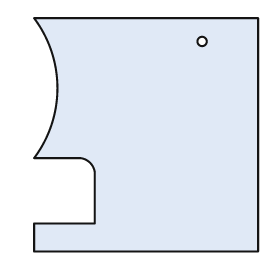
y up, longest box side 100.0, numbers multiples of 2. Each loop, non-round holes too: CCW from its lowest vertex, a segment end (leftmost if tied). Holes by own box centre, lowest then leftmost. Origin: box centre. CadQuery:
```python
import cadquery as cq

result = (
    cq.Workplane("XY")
    .moveTo(-48.0, -50.0)
    .lineTo(48.0, -50.0)
    .lineTo(48.0, 50.0)
    .lineTo(-48.0, 50.0)
    .threePointArc((-38.0, 20.0), (-48.0, -10.0))
    .lineTo(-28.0, -10.0)
    .threePointArc((-24.0, -12.0), (-22.0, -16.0))
    .lineTo(-22.0, -38.0)
    .lineTo(-48.0, -38.0)
    .close()
    .moveTo(24.0, 40.0)
    .circle(2.0)
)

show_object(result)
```